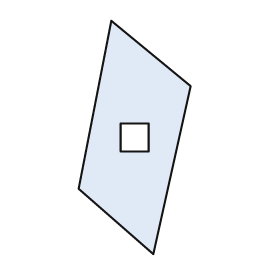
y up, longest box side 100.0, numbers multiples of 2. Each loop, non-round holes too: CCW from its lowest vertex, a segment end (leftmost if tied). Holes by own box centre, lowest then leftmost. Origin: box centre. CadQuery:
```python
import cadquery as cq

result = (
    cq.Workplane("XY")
    .moveTo(8.0, -50.0)
    .lineTo(24.0, 22.0)
    .lineTo(-10.0, 50.0)
    .lineTo(-24.0, -22.0)
    .close()
    .moveTo(-6.0, -6.0)
    .lineTo(6.0, -6.0)
    .lineTo(6.0, 6.0)
    .lineTo(-6.0, 6.0)
    .close()
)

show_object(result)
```